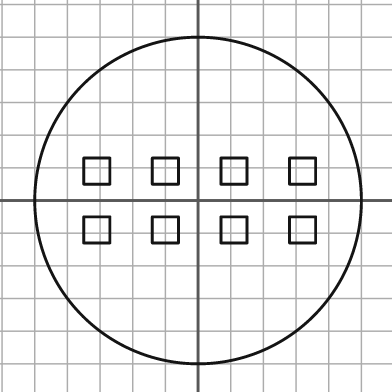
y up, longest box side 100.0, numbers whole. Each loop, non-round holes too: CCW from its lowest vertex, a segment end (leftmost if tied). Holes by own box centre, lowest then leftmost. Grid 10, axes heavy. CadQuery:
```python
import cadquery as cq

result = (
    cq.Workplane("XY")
    .moveTo(0.0, 0.0)
    .circle(50.0)
    .moveTo(-35.0, -13.0)
    .lineTo(-27.0, -13.0)
    .lineTo(-27.0, -5.0)
    .lineTo(-35.0, -5.0)
    .close()
    .moveTo(-14.0, -13.0)
    .lineTo(-6.0, -13.0)
    .lineTo(-6.0, -5.0)
    .lineTo(-14.0, -5.0)
    .close()
    .moveTo(7.0, -13.0)
    .lineTo(15.0, -13.0)
    .lineTo(15.0, -5.0)
    .lineTo(7.0, -5.0)
    .close()
    .moveTo(28.0, -13.0)
    .lineTo(36.0, -13.0)
    .lineTo(36.0, -5.0)
    .lineTo(28.0, -5.0)
    .close()
    .moveTo(-35.0, 5.0)
    .lineTo(-27.0, 5.0)
    .lineTo(-27.0, 13.0)
    .lineTo(-35.0, 13.0)
    .close()
    .moveTo(-14.0, 5.0)
    .lineTo(-6.0, 5.0)
    .lineTo(-6.0, 13.0)
    .lineTo(-14.0, 13.0)
    .close()
    .moveTo(7.0, 5.0)
    .lineTo(15.0, 5.0)
    .lineTo(15.0, 13.0)
    .lineTo(7.0, 13.0)
    .close()
    .moveTo(28.0, 5.0)
    .lineTo(36.0, 5.0)
    .lineTo(36.0, 13.0)
    .lineTo(28.0, 13.0)
    .close()
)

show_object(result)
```